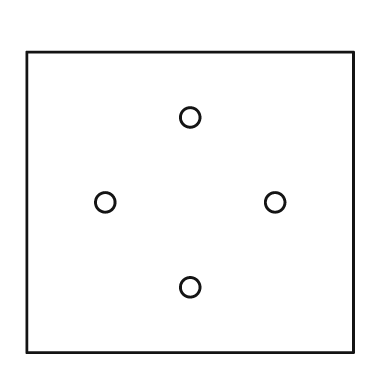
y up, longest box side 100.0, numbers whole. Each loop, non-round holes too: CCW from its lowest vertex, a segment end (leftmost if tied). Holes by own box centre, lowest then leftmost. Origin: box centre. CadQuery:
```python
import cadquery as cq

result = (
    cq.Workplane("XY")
    .moveTo(-50.0, -46.0)
    .lineTo(50.0, -46.0)
    .lineTo(50.0, 46.0)
    .lineTo(-50.0, 46.0)
    .close()
    .moveTo(0.0, -26.0)
    .circle(3.0)
    .moveTo(-26.0, 0.0)
    .circle(3.0)
    .moveTo(26.0, 0.0)
    .circle(3.0)
    .moveTo(0.0, 26.0)
    .circle(3.0)
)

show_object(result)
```